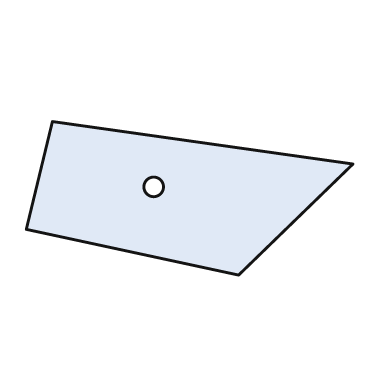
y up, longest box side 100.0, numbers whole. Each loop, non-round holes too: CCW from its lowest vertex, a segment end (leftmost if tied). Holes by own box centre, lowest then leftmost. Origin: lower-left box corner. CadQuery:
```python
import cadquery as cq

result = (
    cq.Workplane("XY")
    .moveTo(65.0, 0.0)
    .lineTo(100.0, 34.0)
    .lineTo(8.0, 47.0)
    .lineTo(0.0, 14.0)
    .close()
    .moveTo(39.0, 27.0)
    .circle(3.0)
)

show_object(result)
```